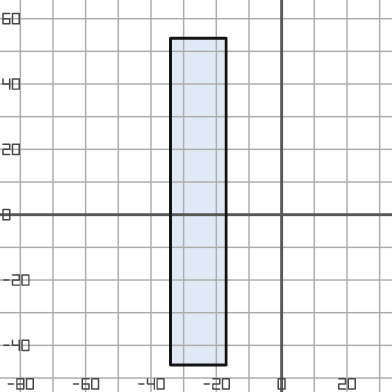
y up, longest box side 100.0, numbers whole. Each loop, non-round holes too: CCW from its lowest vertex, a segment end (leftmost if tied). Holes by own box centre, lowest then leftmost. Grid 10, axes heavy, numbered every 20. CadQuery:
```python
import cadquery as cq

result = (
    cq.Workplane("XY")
    .moveTo(-34.0, -46.0)
    .lineTo(-17.0, -46.0)
    .lineTo(-17.0, 54.0)
    .lineTo(-34.0, 54.0)
    .close()
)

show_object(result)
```